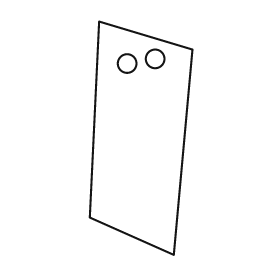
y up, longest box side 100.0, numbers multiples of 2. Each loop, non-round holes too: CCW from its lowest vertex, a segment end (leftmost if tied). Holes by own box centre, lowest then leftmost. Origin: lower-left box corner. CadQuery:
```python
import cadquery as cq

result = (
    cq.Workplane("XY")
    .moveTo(36.0, 0.0)
    .lineTo(44.0, 88.0)
    .lineTo(4.0, 100.0)
    .lineTo(0.0, 16.0)
    .close()
    .moveTo(16.0, 82.0)
    .circle(4.0)
    .moveTo(28.0, 84.0)
    .circle(4.0)
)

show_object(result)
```